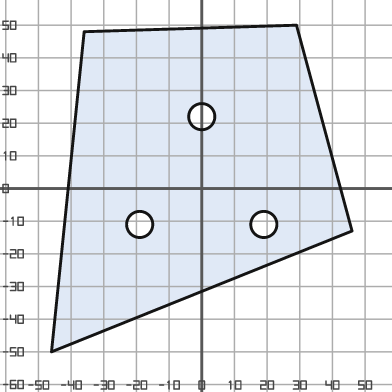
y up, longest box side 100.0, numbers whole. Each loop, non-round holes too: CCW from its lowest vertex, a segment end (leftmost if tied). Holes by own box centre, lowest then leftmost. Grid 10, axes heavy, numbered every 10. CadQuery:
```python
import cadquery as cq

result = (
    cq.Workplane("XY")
    .moveTo(-46.0, -50.0)
    .lineTo(46.0, -13.0)
    .lineTo(29.0, 50.0)
    .lineTo(-36.0, 48.0)
    .close()
    .moveTo(-19.0, -11.0)
    .circle(4.0)
    .moveTo(19.0, -11.0)
    .circle(4.0)
    .moveTo(0.0, 22.0)
    .circle(4.0)
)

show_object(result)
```